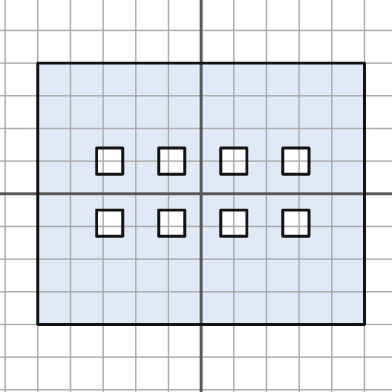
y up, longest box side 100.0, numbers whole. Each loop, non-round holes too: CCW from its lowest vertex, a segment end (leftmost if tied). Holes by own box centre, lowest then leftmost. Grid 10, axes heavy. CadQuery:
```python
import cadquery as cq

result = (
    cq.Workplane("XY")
    .moveTo(-50.0, -40.0)
    .lineTo(50.0, -40.0)
    .lineTo(50.0, 40.0)
    .lineTo(-50.0, 40.0)
    .close()
    .moveTo(-32.0, -13.0)
    .lineTo(-24.0, -13.0)
    .lineTo(-24.0, -5.0)
    .lineTo(-32.0, -5.0)
    .close()
    .moveTo(-13.0, -13.0)
    .lineTo(-5.0, -13.0)
    .lineTo(-5.0, -5.0)
    .lineTo(-13.0, -5.0)
    .close()
    .moveTo(6.0, -13.0)
    .lineTo(14.0, -13.0)
    .lineTo(14.0, -5.0)
    .lineTo(6.0, -5.0)
    .close()
    .moveTo(25.0, -13.0)
    .lineTo(33.0, -13.0)
    .lineTo(33.0, -5.0)
    .lineTo(25.0, -5.0)
    .close()
    .moveTo(-32.0, 6.0)
    .lineTo(-24.0, 6.0)
    .lineTo(-24.0, 14.0)
    .lineTo(-32.0, 14.0)
    .close()
    .moveTo(-13.0, 6.0)
    .lineTo(-5.0, 6.0)
    .lineTo(-5.0, 14.0)
    .lineTo(-13.0, 14.0)
    .close()
    .moveTo(6.0, 6.0)
    .lineTo(14.0, 6.0)
    .lineTo(14.0, 14.0)
    .lineTo(6.0, 14.0)
    .close()
    .moveTo(25.0, 6.0)
    .lineTo(33.0, 6.0)
    .lineTo(33.0, 14.0)
    .lineTo(25.0, 14.0)
    .close()
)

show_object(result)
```